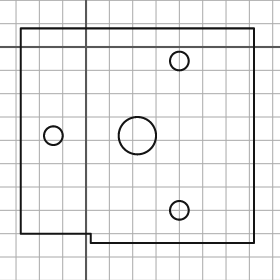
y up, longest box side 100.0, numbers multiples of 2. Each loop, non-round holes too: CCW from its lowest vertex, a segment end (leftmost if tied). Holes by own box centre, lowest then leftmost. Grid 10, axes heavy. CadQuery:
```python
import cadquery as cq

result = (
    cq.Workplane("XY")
    .moveTo(2.0, -84.0)
    .lineTo(72.0, -84.0)
    .lineTo(72.0, 8.0)
    .lineTo(-28.0, 8.0)
    .lineTo(-28.0, -80.0)
    .lineTo(2.0, -80.0)
    .close()
    .moveTo(40.0, -70.0)
    .circle(4.0)
    .moveTo(-14.0, -38.0)
    .circle(4.0)
    .moveTo(22.0, -38.0)
    .circle(8.0)
    .moveTo(40.0, -6.0)
    .circle(4.0)
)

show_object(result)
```